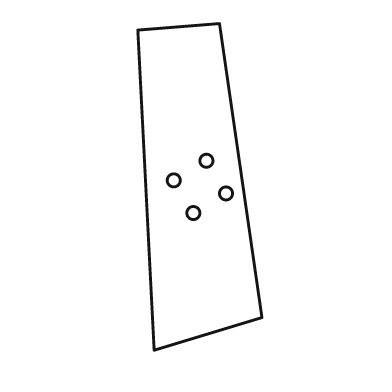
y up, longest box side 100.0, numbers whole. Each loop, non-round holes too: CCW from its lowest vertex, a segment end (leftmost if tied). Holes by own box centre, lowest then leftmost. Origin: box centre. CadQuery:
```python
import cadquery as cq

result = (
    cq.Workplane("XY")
    .moveTo(-14.0, -50.0)
    .lineTo(19.0, -40.0)
    .lineTo(6.0, 50.0)
    .lineTo(-19.0, 48.0)
    .close()
    .moveTo(-2.0, -8.0)
    .circle(2.0)
    .moveTo(8.0, -2.0)
    .circle(2.0)
    .moveTo(-8.0, 2.0)
    .circle(2.0)
    .moveTo(2.0, 8.0)
    .circle(2.0)
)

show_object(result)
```